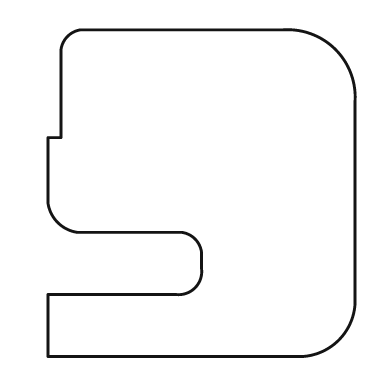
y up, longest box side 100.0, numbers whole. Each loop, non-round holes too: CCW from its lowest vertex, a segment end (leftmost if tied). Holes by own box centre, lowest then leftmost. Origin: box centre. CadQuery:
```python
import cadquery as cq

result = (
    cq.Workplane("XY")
    .moveTo(-47.0, -50.0)
    .lineTo(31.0, -50.0)
    .threePointArc((42.0, -45.0), (47.0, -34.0))
    .lineTo(47.0, 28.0)
    .threePointArc((41.0, 44.0), (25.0, 50.0))
    .lineTo(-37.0, 50.0)
    .threePointArc((-41.0, 48.0), (-43.0, 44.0))
    .lineTo(-43.0, 17.0)
    .lineTo(-47.0, 17.0)
    .lineTo(-47.0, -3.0)
    .threePointArc((-44.0, -9.0), (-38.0, -12.0))
    .lineTo(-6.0, -12.0)
    .threePointArc((-2.0, -14.0), (0.0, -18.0))
    .lineTo(0.0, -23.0)
    .threePointArc((-2.0, -29.0), (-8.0, -31.0))
    .lineTo(-47.0, -31.0)
    .close()
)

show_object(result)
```